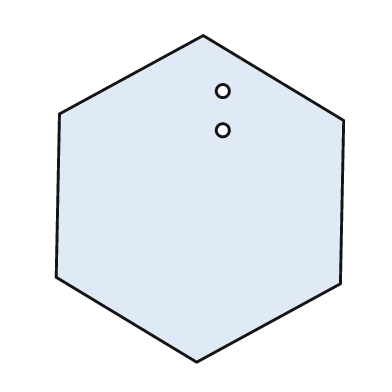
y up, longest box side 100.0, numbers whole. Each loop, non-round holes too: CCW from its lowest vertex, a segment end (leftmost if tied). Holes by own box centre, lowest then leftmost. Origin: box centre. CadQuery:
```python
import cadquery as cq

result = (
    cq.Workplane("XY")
    .moveTo(-1.0, -50.0)
    .lineTo(43.0, -26.0)
    .lineTo(44.0, 24.0)
    .lineTo(1.0, 50.0)
    .lineTo(-43.0, 26.0)
    .lineTo(-44.0, -24.0)
    .close()
    .moveTo(7.0, 21.0)
    .circle(2.0)
    .moveTo(7.0, 33.0)
    .circle(2.0)
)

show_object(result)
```